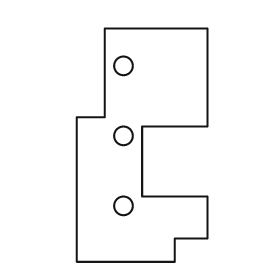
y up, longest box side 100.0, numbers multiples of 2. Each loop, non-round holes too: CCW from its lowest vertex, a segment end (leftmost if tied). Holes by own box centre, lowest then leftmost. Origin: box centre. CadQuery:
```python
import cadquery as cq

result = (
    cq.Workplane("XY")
    .moveTo(-28.0, -50.0)
    .lineTo(14.0, -50.0)
    .lineTo(14.0, -40.0)
    .lineTo(28.0, -40.0)
    .lineTo(28.0, -22.0)
    .lineTo(0.0, -22.0)
    .lineTo(0.0, 8.0)
    .lineTo(28.0, 8.0)
    .lineTo(28.0, 50.0)
    .lineTo(-16.0, 50.0)
    .lineTo(-16.0, 12.0)
    .lineTo(-28.0, 12.0)
    .close()
    .moveTo(-8.0, -26.0)
    .circle(4.0)
    .moveTo(-8.0, 4.0)
    .circle(4.0)
    .moveTo(-8.0, 34.0)
    .circle(4.0)
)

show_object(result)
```